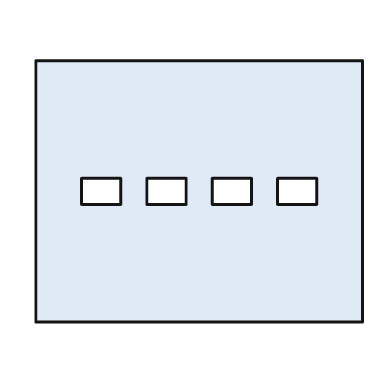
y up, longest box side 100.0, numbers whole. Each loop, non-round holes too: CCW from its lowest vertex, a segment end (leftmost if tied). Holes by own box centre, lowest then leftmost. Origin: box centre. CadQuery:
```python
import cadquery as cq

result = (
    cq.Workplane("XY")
    .moveTo(-50.0, -40.0)
    .lineTo(50.0, -40.0)
    .lineTo(50.0, 40.0)
    .lineTo(-50.0, 40.0)
    .close()
    .moveTo(-36.0, -4.0)
    .lineTo(-24.0, -4.0)
    .lineTo(-24.0, 4.0)
    .lineTo(-36.0, 4.0)
    .close()
    .moveTo(-16.0, -4.0)
    .lineTo(-4.0, -4.0)
    .lineTo(-4.0, 4.0)
    .lineTo(-16.0, 4.0)
    .close()
    .moveTo(4.0, -4.0)
    .lineTo(16.0, -4.0)
    .lineTo(16.0, 4.0)
    .lineTo(4.0, 4.0)
    .close()
    .moveTo(24.0, -4.0)
    .lineTo(36.0, -4.0)
    .lineTo(36.0, 4.0)
    .lineTo(24.0, 4.0)
    .close()
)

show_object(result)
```